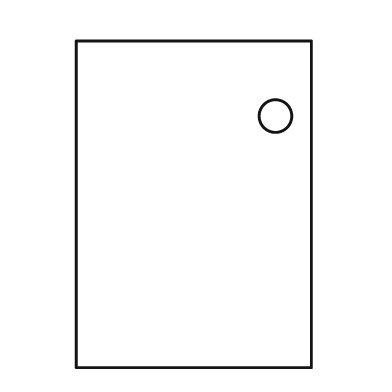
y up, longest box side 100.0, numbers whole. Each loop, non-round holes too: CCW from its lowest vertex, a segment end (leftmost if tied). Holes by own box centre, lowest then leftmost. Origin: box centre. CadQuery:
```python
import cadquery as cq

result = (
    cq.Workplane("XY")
    .moveTo(-36.0, -50.0)
    .lineTo(36.0, -50.0)
    .lineTo(36.0, 50.0)
    .lineTo(-36.0, 50.0)
    .close()
    .moveTo(25.0, 27.0)
    .circle(5.0)
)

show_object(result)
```